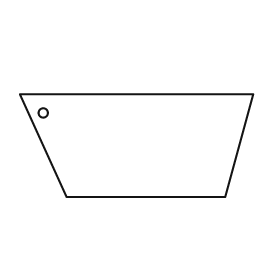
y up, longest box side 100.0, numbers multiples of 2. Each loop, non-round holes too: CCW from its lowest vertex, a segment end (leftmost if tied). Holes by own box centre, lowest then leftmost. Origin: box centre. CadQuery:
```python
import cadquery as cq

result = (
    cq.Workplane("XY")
    .moveTo(-30.0, -22.0)
    .lineTo(38.0, -22.0)
    .lineTo(50.0, 22.0)
    .lineTo(-50.0, 22.0)
    .close()
    .moveTo(-40.0, 14.0)
    .circle(2.0)
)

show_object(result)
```